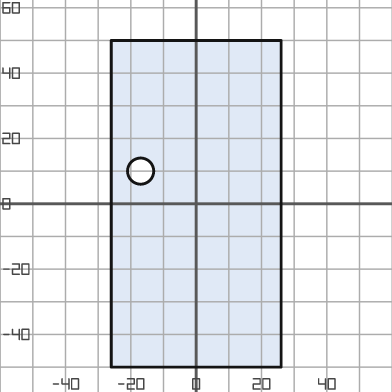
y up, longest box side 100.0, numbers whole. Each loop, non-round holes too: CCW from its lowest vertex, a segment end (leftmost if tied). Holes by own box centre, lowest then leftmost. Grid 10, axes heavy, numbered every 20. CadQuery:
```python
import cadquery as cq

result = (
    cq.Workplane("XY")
    .moveTo(-26.0, -50.0)
    .lineTo(26.0, -50.0)
    .lineTo(26.0, 50.0)
    .lineTo(-26.0, 50.0)
    .close()
    .moveTo(-17.0, 10.0)
    .circle(4.0)
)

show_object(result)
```